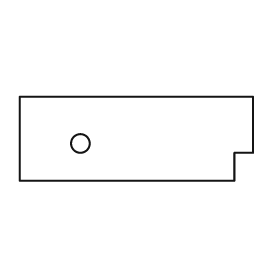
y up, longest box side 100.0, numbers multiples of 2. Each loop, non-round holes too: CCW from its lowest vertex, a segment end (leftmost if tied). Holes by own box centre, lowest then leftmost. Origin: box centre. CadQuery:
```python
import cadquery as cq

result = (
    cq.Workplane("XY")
    .moveTo(-50.0, -18.0)
    .lineTo(42.0, -18.0)
    .lineTo(42.0, -6.0)
    .lineTo(50.0, -6.0)
    .lineTo(50.0, 18.0)
    .lineTo(-50.0, 18.0)
    .close()
    .moveTo(-24.0, -2.0)
    .circle(4.0)
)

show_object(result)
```